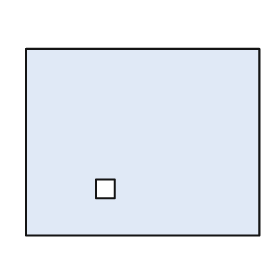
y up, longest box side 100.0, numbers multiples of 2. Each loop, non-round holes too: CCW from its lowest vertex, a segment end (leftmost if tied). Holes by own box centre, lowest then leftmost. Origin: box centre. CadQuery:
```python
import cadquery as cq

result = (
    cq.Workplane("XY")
    .moveTo(-50.0, -40.0)
    .lineTo(50.0, -40.0)
    .lineTo(50.0, 40.0)
    .lineTo(-50.0, 40.0)
    .close()
    .moveTo(-20.0, -24.0)
    .lineTo(-12.0, -24.0)
    .lineTo(-12.0, -16.0)
    .lineTo(-20.0, -16.0)
    .close()
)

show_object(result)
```